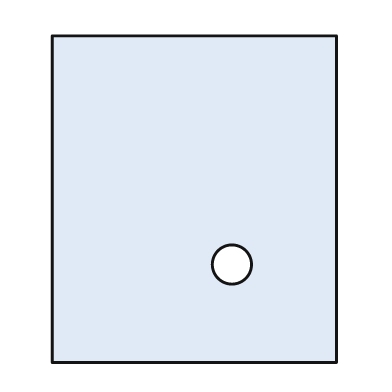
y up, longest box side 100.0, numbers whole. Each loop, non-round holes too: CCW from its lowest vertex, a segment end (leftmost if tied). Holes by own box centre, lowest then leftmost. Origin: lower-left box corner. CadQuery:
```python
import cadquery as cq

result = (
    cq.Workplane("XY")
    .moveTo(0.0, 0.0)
    .lineTo(87.0, 0.0)
    .lineTo(87.0, 100.0)
    .lineTo(0.0, 100.0)
    .close()
    .moveTo(55.0, 30.0)
    .circle(6.0)
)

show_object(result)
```